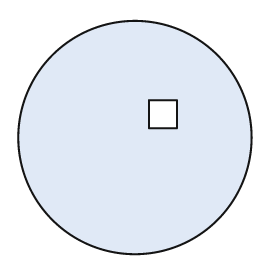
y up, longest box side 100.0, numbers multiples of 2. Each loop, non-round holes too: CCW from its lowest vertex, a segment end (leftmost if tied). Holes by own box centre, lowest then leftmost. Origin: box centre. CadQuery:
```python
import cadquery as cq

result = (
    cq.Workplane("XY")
    .moveTo(0.0, 0.0)
    .circle(50.0)
    .moveTo(6.0, 4.0)
    .lineTo(18.0, 4.0)
    .lineTo(18.0, 16.0)
    .lineTo(6.0, 16.0)
    .close()
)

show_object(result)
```